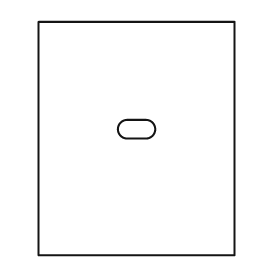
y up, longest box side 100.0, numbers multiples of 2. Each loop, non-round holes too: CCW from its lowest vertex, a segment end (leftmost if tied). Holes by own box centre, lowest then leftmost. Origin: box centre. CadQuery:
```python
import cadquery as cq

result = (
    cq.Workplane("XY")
    .moveTo(-42.0, -50.0)
    .lineTo(42.0, -50.0)
    .lineTo(42.0, 50.0)
    .lineTo(-42.0, 50.0)
    .close()
    .moveTo(-4.0, 0.0)
    .lineTo(4.0, 0.0)
    .threePointArc((8.0, 4.0), (4.0, 8.0))
    .lineTo(-4.0, 8.0)
    .threePointArc((-8.0, 4.0), (-4.0, 0.0))
    .close()
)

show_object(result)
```